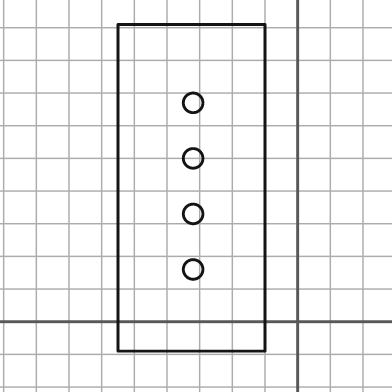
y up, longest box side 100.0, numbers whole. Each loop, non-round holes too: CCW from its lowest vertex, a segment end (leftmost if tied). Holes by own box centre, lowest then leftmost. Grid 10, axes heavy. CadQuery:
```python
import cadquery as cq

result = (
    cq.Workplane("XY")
    .moveTo(-55.0, -9.0)
    .lineTo(-10.0, -9.0)
    .lineTo(-10.0, 91.0)
    .lineTo(-55.0, 91.0)
    .close()
    .moveTo(-32.0, 16.0)
    .circle(3.0)
    .moveTo(-32.0, 33.0)
    .circle(3.0)
    .moveTo(-32.0, 50.0)
    .circle(3.0)
    .moveTo(-32.0, 67.0)
    .circle(3.0)
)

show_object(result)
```